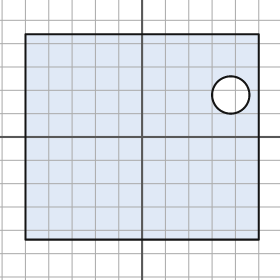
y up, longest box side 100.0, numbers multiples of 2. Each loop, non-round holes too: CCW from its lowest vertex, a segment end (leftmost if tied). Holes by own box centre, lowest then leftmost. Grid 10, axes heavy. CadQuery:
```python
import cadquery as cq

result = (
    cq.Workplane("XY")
    .moveTo(-50.0, -44.0)
    .lineTo(50.0, -44.0)
    .lineTo(50.0, 44.0)
    .lineTo(-50.0, 44.0)
    .close()
    .moveTo(38.0, 18.0)
    .circle(8.0)
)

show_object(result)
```